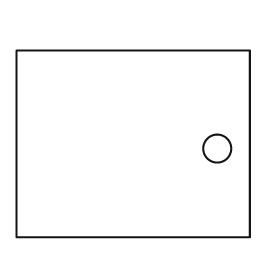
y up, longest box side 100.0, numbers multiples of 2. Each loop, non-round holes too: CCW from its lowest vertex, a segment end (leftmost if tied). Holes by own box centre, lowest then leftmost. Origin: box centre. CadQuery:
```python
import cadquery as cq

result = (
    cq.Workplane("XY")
    .moveTo(-50.0, -40.0)
    .lineTo(50.0, -40.0)
    .lineTo(50.0, 40.0)
    .lineTo(-50.0, 40.0)
    .close()
    .moveTo(36.0, -2.0)
    .circle(6.0)
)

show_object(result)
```